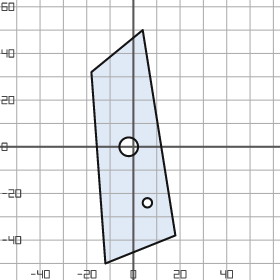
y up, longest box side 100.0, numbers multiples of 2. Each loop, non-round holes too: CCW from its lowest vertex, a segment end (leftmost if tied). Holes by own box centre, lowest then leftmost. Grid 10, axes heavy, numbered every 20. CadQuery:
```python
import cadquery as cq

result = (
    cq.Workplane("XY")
    .moveTo(-12.0, -50.0)
    .lineTo(18.0, -38.0)
    .lineTo(4.0, 50.0)
    .lineTo(-18.0, 32.0)
    .close()
    .moveTo(6.0, -24.0)
    .circle(2.0)
    .moveTo(-2.0, 0.0)
    .circle(4.0)
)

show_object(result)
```